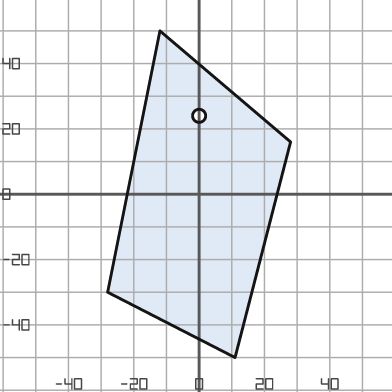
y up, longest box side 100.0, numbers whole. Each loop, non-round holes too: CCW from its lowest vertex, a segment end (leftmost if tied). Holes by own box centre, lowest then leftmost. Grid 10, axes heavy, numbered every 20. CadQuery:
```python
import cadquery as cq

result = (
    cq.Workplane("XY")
    .moveTo(11.0, -50.0)
    .lineTo(28.0, 16.0)
    .lineTo(-12.0, 50.0)
    .lineTo(-28.0, -30.0)
    .close()
    .moveTo(0.0, 24.0)
    .circle(2.0)
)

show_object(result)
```